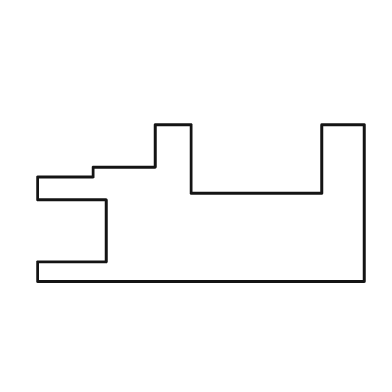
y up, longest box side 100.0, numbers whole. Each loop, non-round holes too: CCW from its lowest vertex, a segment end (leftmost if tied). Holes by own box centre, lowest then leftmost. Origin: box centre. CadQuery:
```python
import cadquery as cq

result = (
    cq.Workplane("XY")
    .moveTo(-50.0, -24.0)
    .lineTo(50.0, -24.0)
    .lineTo(50.0, 24.0)
    .lineTo(37.0, 24.0)
    .lineTo(37.0, 3.0)
    .lineTo(-3.0, 3.0)
    .lineTo(-3.0, 24.0)
    .lineTo(-14.0, 24.0)
    .lineTo(-14.0, 11.0)
    .lineTo(-33.0, 11.0)
    .lineTo(-33.0, 8.0)
    .lineTo(-50.0, 8.0)
    .lineTo(-50.0, 1.0)
    .lineTo(-29.0, 1.0)
    .lineTo(-29.0, -18.0)
    .lineTo(-50.0, -18.0)
    .close()
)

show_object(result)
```